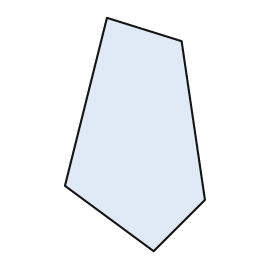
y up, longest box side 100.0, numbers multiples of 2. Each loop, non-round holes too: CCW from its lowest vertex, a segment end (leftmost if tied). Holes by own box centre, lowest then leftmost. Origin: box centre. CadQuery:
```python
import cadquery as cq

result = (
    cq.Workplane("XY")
    .moveTo(8.0, -50.0)
    .lineTo(30.0, -28.0)
    .lineTo(20.0, 40.0)
    .lineTo(-12.0, 50.0)
    .lineTo(-30.0, -22.0)
    .close()
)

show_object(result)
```